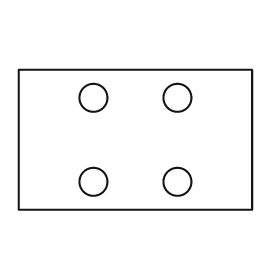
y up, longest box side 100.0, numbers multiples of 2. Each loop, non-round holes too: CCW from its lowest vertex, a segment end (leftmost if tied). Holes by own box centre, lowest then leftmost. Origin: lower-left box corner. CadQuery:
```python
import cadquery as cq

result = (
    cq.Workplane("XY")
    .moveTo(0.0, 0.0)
    .lineTo(100.0, 0.0)
    .lineTo(100.0, 60.0)
    .lineTo(0.0, 60.0)
    .close()
    .moveTo(32.0, 12.0)
    .circle(6.0)
    .moveTo(68.0, 12.0)
    .circle(6.0)
    .moveTo(32.0, 48.0)
    .circle(6.0)
    .moveTo(68.0, 48.0)
    .circle(6.0)
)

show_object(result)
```